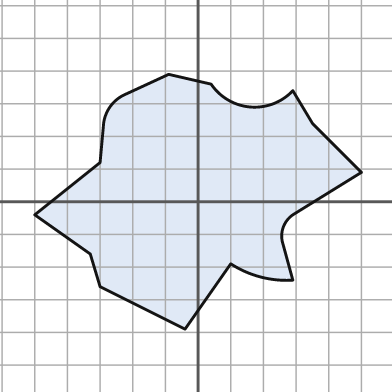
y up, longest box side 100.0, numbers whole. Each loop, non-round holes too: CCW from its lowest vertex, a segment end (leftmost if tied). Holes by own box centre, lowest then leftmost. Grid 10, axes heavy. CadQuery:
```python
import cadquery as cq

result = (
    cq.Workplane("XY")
    .moveTo(-4.0, -39.0)
    .lineTo(10.0, -19.0)
    .threePointArc((19.0, -23.0), (29.0, -24.0))
    .lineTo(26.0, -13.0)
    .threePointArc((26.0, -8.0), (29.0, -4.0))
    .lineTo(50.0, 9.0)
    .lineTo(35.0, 24.0)
    .lineTo(29.0, 34.0)
    .threePointArc((16.0, 29.0), (4.0, 36.0))
    .lineTo(-9.0, 39.0)
    .lineTo(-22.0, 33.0)
    .threePointArc((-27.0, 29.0), (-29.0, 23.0))
    .lineTo(-30.0, 12.0)
    .lineTo(-50.0, -4.0)
    .lineTo(-33.0, -16.0)
    .lineTo(-30.0, -26.0)
    .close()
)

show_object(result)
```